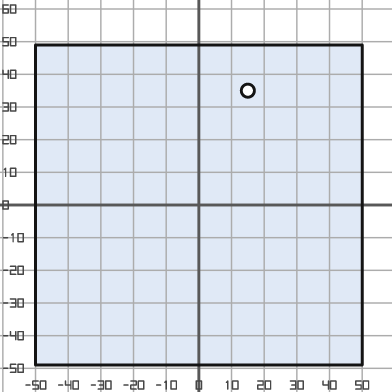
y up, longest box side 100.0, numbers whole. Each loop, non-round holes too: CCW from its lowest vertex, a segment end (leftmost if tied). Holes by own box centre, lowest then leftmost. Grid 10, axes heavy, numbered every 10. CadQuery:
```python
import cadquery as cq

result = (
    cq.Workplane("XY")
    .moveTo(-50.0, -49.0)
    .lineTo(50.0, -49.0)
    .lineTo(50.0, 49.0)
    .lineTo(-50.0, 49.0)
    .close()
    .moveTo(15.0, 35.0)
    .circle(2.0)
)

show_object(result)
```